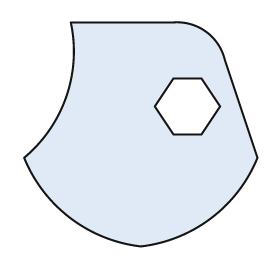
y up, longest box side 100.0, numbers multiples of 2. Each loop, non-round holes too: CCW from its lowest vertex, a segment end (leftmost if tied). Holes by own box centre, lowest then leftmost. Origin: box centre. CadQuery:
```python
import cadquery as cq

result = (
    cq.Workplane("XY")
    .moveTo(0.0, -48.0)
    .threePointArc((30.0, -36.0), (50.0, -10.0))
    .lineTo(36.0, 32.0)
    .threePointArc((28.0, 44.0), (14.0, 48.0))
    .lineTo(-30.0, 48.0)
    .threePointArc((-32.0, 16.0), (-50.0, -10.0))
    .threePointArc((-30.0, -36.0), (0.0, -48.0))
    .close()
    .moveTo(14.0, 0.0)
    .lineTo(26.0, 0.0)
    .lineTo(34.0, 12.0)
    .lineTo(26.0, 24.0)
    .lineTo(14.0, 24.0)
    .lineTo(6.0, 12.0)
    .close()
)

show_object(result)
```